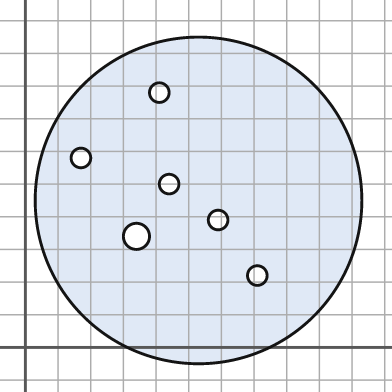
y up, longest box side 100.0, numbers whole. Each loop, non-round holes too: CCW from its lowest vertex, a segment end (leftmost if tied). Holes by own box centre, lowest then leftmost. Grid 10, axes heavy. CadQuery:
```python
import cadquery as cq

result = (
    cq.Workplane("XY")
    .moveTo(53.0, 45.0)
    .circle(50.0)
    .moveTo(71.0, 22.0)
    .circle(3.0)
    .moveTo(34.0, 34.0)
    .circle(4.0)
    .moveTo(59.0, 39.0)
    .circle(3.0)
    .moveTo(44.0, 50.0)
    .circle(3.0)
    .moveTo(17.0, 58.0)
    .circle(3.0)
    .moveTo(41.0, 78.0)
    .circle(3.0)
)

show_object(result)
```